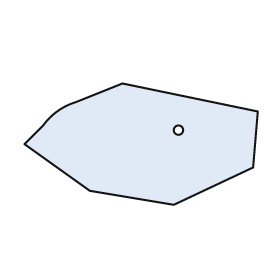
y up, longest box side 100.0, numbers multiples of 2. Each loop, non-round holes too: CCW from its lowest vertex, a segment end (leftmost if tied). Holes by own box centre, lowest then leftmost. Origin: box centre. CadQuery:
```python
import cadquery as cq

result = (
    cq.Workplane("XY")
    .moveTo(14.0, -26.0)
    .lineTo(48.0, -10.0)
    .lineTo(50.0, 14.0)
    .lineTo(-8.0, 26.0)
    .lineTo(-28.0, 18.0)
    .threePointArc((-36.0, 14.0), (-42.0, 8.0))
    .lineTo(-50.0, 0.0)
    .lineTo(-22.0, -20.0)
    .close()
    .moveTo(16.0, 6.0)
    .circle(2.0)
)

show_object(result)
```